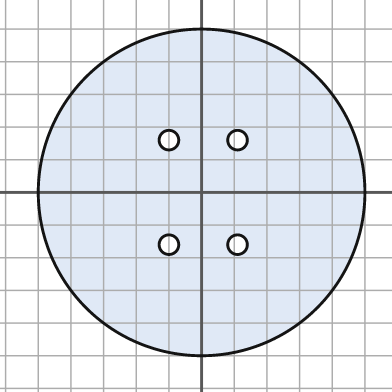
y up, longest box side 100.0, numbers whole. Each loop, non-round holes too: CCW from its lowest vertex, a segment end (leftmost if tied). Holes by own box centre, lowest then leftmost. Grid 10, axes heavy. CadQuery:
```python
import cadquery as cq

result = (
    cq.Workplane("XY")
    .moveTo(0.0, 0.0)
    .circle(50.0)
    .moveTo(-10.0, -16.0)
    .circle(3.0)
    .moveTo(11.0, -16.0)
    .circle(3.0)
    .moveTo(-10.0, 16.0)
    .circle(3.0)
    .moveTo(11.0, 16.0)
    .circle(3.0)
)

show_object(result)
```